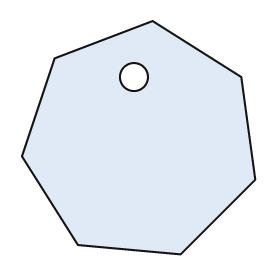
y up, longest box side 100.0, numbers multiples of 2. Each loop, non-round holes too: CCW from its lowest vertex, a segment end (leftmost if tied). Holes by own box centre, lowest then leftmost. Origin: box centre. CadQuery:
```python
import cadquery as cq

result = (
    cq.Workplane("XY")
    .moveTo(18.0, -50.0)
    .lineTo(50.0, -18.0)
    .lineTo(44.0, 26.0)
    .lineTo(6.0, 50.0)
    .lineTo(-36.0, 34.0)
    .lineTo(-50.0, -8.0)
    .lineTo(-26.0, -46.0)
    .close()
    .moveTo(-2.0, 26.0)
    .circle(6.0)
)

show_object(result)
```